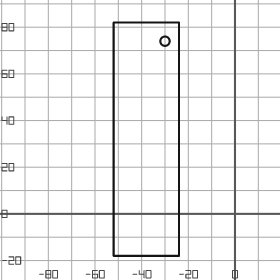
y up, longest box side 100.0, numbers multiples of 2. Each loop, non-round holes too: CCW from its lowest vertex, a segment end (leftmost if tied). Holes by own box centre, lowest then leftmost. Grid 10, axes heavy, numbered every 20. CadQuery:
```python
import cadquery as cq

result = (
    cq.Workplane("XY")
    .moveTo(-52.0, -18.0)
    .lineTo(-24.0, -18.0)
    .lineTo(-24.0, 82.0)
    .lineTo(-52.0, 82.0)
    .close()
    .moveTo(-30.0, 74.0)
    .circle(2.0)
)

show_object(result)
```